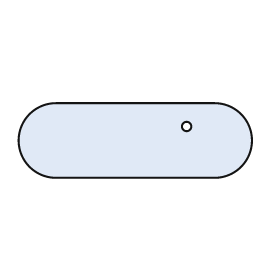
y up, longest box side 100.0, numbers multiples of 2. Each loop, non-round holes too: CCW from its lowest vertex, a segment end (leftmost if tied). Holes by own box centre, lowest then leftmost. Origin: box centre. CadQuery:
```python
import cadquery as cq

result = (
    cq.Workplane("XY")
    .moveTo(-34.0, -16.0)
    .lineTo(34.0, -16.0)
    .threePointArc((50.0, 0.0), (34.0, 16.0))
    .lineTo(-34.0, 16.0)
    .threePointArc((-50.0, 0.0), (-34.0, -16.0))
    .close()
    .moveTo(22.0, 6.0)
    .circle(2.0)
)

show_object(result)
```